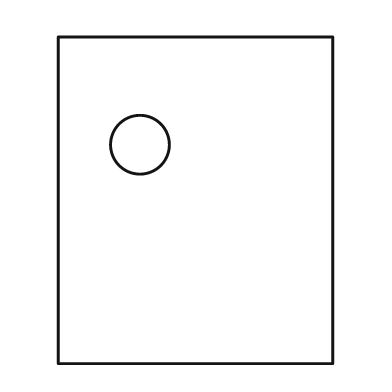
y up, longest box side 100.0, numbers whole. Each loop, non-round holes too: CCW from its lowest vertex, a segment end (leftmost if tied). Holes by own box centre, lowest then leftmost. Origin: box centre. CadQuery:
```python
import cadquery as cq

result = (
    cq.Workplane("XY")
    .moveTo(-42.0, -50.0)
    .lineTo(42.0, -50.0)
    .lineTo(42.0, 50.0)
    .lineTo(-42.0, 50.0)
    .close()
    .moveTo(-17.0, 17.0)
    .circle(9.0)
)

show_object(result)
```